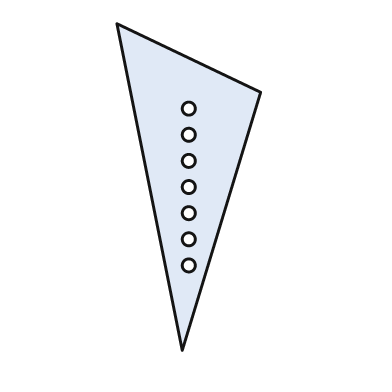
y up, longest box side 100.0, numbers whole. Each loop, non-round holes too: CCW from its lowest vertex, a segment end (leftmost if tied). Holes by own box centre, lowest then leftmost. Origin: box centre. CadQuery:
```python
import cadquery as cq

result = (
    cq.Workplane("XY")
    .moveTo(-2.0, -50.0)
    .lineTo(22.0, 29.0)
    .lineTo(-22.0, 50.0)
    .close()
    .moveTo(0.0, -24.0)
    .circle(2.0)
    .moveTo(0.0, -16.0)
    .circle(2.0)
    .moveTo(0.0, -8.0)
    .circle(2.0)
    .moveTo(0.0, 0.0)
    .circle(2.0)
    .moveTo(0.0, 8.0)
    .circle(2.0)
    .moveTo(0.0, 16.0)
    .circle(2.0)
    .moveTo(0.0, 24.0)
    .circle(2.0)
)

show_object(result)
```